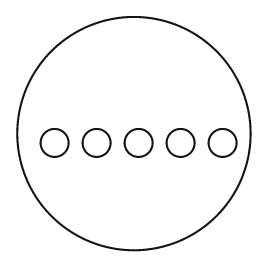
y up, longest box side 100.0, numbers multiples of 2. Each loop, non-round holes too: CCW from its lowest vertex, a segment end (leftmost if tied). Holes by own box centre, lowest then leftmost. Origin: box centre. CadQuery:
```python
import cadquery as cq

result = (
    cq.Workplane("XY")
    .moveTo(0.0, 0.0)
    .circle(50.0)
    .moveTo(-34.0, -4.0)
    .circle(6.0)
    .moveTo(-16.0, -4.0)
    .circle(6.0)
    .moveTo(2.0, -4.0)
    .circle(6.0)
    .moveTo(20.0, -4.0)
    .circle(6.0)
    .moveTo(38.0, -4.0)
    .circle(6.0)
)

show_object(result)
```